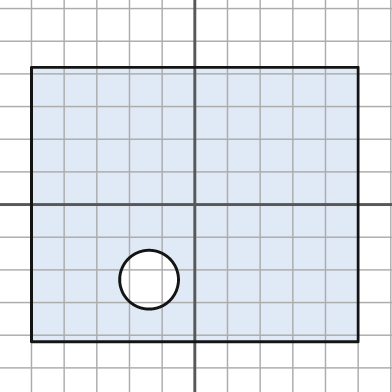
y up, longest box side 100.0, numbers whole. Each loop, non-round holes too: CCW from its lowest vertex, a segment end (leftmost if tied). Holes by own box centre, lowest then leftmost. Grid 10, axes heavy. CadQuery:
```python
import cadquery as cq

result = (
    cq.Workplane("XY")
    .moveTo(-50.0, -42.0)
    .lineTo(50.0, -42.0)
    .lineTo(50.0, 42.0)
    .lineTo(-50.0, 42.0)
    .close()
    .moveTo(-14.0, -23.0)
    .circle(9.0)
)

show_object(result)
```